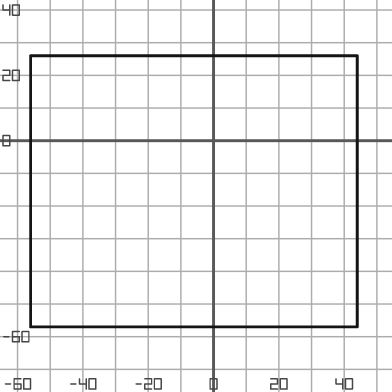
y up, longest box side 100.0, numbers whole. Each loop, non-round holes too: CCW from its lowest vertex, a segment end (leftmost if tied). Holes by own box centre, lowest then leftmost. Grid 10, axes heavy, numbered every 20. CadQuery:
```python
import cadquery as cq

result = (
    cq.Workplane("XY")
    .moveTo(-56.0, -57.0)
    .lineTo(44.0, -57.0)
    .lineTo(44.0, 26.0)
    .lineTo(-56.0, 26.0)
    .close()
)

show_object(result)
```